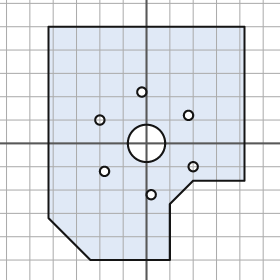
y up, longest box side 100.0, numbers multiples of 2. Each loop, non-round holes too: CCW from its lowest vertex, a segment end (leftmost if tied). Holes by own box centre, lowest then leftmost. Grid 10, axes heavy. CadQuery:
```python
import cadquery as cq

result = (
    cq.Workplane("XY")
    .moveTo(-24.0, -50.0)
    .lineTo(10.0, -50.0)
    .lineTo(10.0, -26.0)
    .lineTo(20.0, -16.0)
    .lineTo(42.0, -16.0)
    .lineTo(42.0, 50.0)
    .lineTo(-42.0, 50.0)
    .lineTo(-42.0, -32.0)
    .close()
    .moveTo(2.0, -22.0)
    .circle(2.0)
    .moveTo(-18.0, -12.0)
    .circle(2.0)
    .moveTo(20.0, -10.0)
    .circle(2.0)
    .moveTo(0.0, 0.0)
    .circle(8.0)
    .moveTo(-20.0, 10.0)
    .circle(2.0)
    .moveTo(18.0, 12.0)
    .circle(2.0)
    .moveTo(-2.0, 22.0)
    .circle(2.0)
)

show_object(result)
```